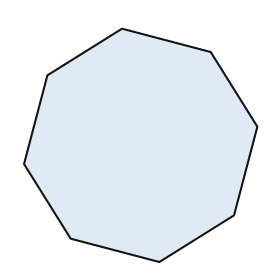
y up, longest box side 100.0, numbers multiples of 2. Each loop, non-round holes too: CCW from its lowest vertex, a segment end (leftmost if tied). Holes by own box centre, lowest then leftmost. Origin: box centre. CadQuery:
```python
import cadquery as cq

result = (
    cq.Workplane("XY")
    .moveTo(8.0, -50.0)
    .lineTo(40.0, -30.0)
    .lineTo(50.0, 8.0)
    .lineTo(30.0, 40.0)
    .lineTo(-8.0, 50.0)
    .lineTo(-40.0, 30.0)
    .lineTo(-50.0, -8.0)
    .lineTo(-30.0, -40.0)
    .close()
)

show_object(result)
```